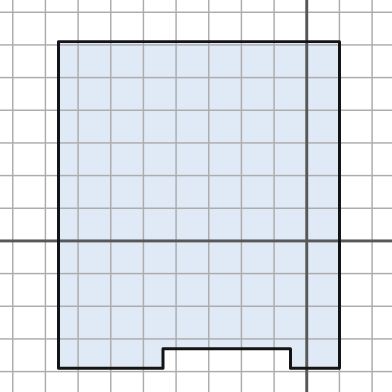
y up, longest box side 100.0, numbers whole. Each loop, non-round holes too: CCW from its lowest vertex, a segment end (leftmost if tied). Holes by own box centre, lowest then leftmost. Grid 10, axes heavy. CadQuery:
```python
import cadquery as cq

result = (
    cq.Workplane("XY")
    .moveTo(-76.0, -39.0)
    .lineTo(-44.0, -39.0)
    .lineTo(-44.0, -33.0)
    .lineTo(-5.0, -33.0)
    .lineTo(-5.0, -39.0)
    .lineTo(10.0, -39.0)
    .lineTo(10.0, 61.0)
    .lineTo(-76.0, 61.0)
    .close()
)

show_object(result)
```